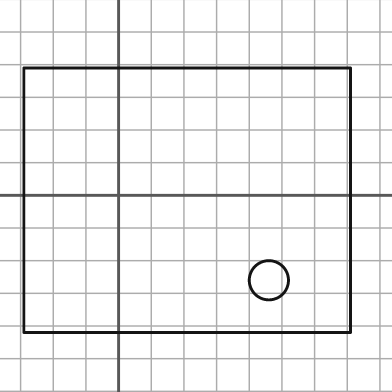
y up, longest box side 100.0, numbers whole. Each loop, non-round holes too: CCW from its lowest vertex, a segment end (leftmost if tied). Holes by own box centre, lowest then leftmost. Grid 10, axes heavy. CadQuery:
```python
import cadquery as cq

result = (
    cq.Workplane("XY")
    .moveTo(-29.0, -42.0)
    .lineTo(71.0, -42.0)
    .lineTo(71.0, 39.0)
    .lineTo(-29.0, 39.0)
    .close()
    .moveTo(46.0, -26.0)
    .circle(6.0)
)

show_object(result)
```